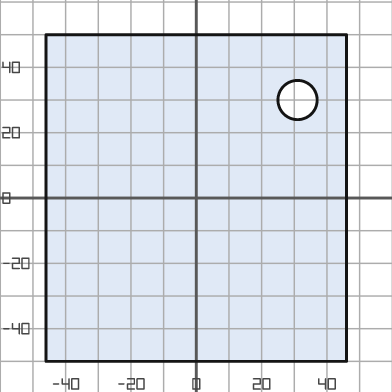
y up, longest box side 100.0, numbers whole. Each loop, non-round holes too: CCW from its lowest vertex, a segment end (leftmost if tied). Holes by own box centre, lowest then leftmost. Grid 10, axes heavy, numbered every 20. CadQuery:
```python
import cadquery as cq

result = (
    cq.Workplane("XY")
    .moveTo(-46.0, -50.0)
    .lineTo(46.0, -50.0)
    .lineTo(46.0, 50.0)
    .lineTo(-46.0, 50.0)
    .close()
    .moveTo(31.0, 30.0)
    .circle(6.0)
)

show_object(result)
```